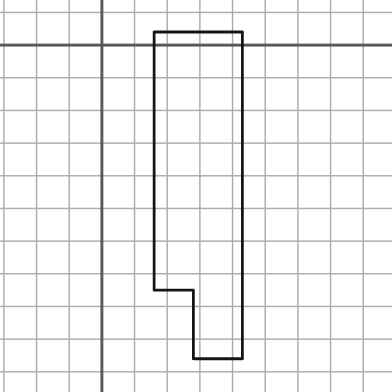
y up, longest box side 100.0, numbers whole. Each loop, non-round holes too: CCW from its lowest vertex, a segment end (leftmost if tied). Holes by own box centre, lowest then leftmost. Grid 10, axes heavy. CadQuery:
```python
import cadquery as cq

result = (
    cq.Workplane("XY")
    .moveTo(28.0, -96.0)
    .lineTo(43.0, -96.0)
    .lineTo(43.0, 4.0)
    .lineTo(16.0, 4.0)
    .lineTo(16.0, -75.0)
    .lineTo(28.0, -75.0)
    .close()
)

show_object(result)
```